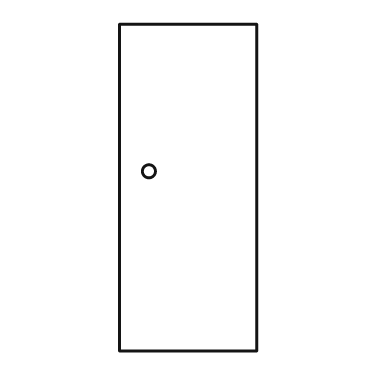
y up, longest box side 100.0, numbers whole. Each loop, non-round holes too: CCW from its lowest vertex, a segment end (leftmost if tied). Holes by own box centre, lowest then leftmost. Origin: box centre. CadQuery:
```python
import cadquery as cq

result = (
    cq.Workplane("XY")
    .moveTo(-21.0, -50.0)
    .lineTo(21.0, -50.0)
    .lineTo(21.0, 50.0)
    .lineTo(-21.0, 50.0)
    .close()
    .moveTo(-12.0, 5.0)
    .circle(2.0)
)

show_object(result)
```